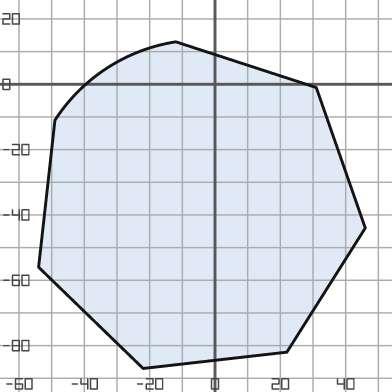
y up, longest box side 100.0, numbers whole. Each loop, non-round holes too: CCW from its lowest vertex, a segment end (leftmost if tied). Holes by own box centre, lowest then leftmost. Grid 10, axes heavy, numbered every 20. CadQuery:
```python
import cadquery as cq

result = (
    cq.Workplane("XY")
    .moveTo(-22.0, -87.0)
    .lineTo(22.0, -82.0)
    .lineTo(46.0, -44.0)
    .lineTo(31.0, -1.0)
    .lineTo(-12.0, 13.0)
    .threePointArc((-33.0, 5.0), (-49.0, -11.0))
    .lineTo(-54.0, -56.0)
    .close()
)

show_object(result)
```